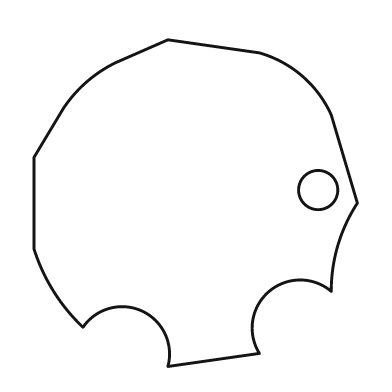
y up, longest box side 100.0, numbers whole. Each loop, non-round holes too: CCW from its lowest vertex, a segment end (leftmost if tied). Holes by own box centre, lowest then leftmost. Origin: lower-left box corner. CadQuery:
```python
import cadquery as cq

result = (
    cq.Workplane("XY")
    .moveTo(41.0, 0.0)
    .lineTo(69.0, 4.0)
    .threePointArc((72.0, 23.0), (91.0, 23.0))
    .threePointArc((93.0, 37.0), (99.0, 50.0))
    .lineTo(91.0, 77.0)
    .threePointArc((82.0, 89.0), (69.0, 96.0))
    .lineTo(41.0, 100.0)
    .lineTo(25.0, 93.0)
    .threePointArc((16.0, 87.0), (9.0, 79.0))
    .lineTo(0.0, 64.0)
    .lineTo(0.0, 36.0)
    .threePointArc((6.0, 23.0), (15.0, 12.0))
    .threePointArc((33.0, 17.0), (41.0, 0.0))
    .close()
    .moveTo(87.0, 54.0)
    .circle(6.0)
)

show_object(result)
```